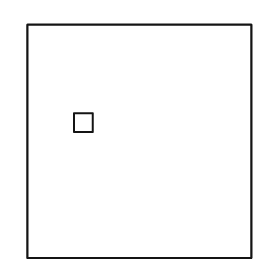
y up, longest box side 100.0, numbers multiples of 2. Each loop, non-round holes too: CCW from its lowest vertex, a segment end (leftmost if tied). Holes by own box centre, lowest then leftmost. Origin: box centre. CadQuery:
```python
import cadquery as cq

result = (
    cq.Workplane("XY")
    .moveTo(-48.0, -50.0)
    .lineTo(48.0, -50.0)
    .lineTo(48.0, 50.0)
    .lineTo(-48.0, 50.0)
    .close()
    .moveTo(-28.0, 4.0)
    .lineTo(-20.0, 4.0)
    .lineTo(-20.0, 12.0)
    .lineTo(-28.0, 12.0)
    .close()
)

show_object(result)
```